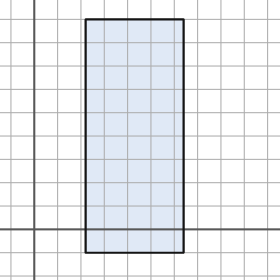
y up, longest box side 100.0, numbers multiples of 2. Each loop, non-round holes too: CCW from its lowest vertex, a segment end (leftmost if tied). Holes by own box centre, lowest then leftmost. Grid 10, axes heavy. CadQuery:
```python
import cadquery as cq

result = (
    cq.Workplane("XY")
    .moveTo(22.0, -10.0)
    .lineTo(64.0, -10.0)
    .lineTo(64.0, 90.0)
    .lineTo(22.0, 90.0)
    .close()
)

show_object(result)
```